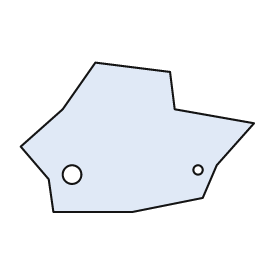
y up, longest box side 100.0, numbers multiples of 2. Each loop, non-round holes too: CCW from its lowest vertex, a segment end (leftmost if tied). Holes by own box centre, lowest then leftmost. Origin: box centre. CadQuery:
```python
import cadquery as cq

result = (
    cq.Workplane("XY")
    .moveTo(-36.0, -32.0)
    .lineTo(-2.0, -32.0)
    .lineTo(28.0, -26.0)
    .lineTo(34.0, -12.0)
    .lineTo(50.0, 6.0)
    .lineTo(16.0, 12.0)
    .lineTo(14.0, 28.0)
    .lineTo(-18.0, 32.0)
    .lineTo(-32.0, 12.0)
    .lineTo(-50.0, -4.0)
    .lineTo(-38.0, -18.0)
    .close()
    .moveTo(-28.0, -16.0)
    .circle(4.0)
    .moveTo(26.0, -14.0)
    .circle(2.0)
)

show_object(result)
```